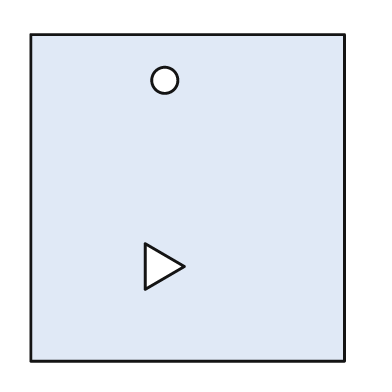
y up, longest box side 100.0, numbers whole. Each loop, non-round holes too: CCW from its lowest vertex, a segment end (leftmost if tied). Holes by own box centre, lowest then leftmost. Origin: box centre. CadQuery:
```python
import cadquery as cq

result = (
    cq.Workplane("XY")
    .moveTo(-48.0, -50.0)
    .lineTo(48.0, -50.0)
    .lineTo(48.0, 50.0)
    .lineTo(-48.0, 50.0)
    .close()
    .moveTo(-13.0, -28.0)
    .lineTo(-1.0, -21.0)
    .lineTo(-13.0, -14.0)
    .close()
    .moveTo(-7.0, 36.0)
    .circle(4.0)
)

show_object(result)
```